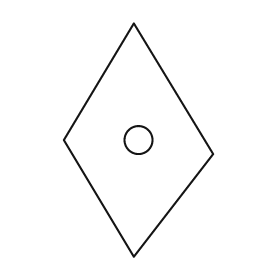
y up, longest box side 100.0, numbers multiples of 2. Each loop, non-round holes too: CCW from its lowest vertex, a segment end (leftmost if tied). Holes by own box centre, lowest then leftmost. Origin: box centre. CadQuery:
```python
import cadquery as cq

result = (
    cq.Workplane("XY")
    .moveTo(-2.0, -50.0)
    .lineTo(32.0, -6.0)
    .lineTo(-2.0, 50.0)
    .lineTo(-32.0, 0.0)
    .close()
    .moveTo(0.0, 0.0)
    .circle(6.0)
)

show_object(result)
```